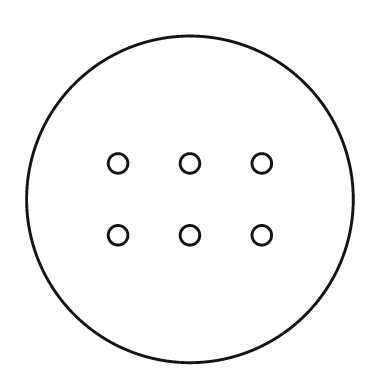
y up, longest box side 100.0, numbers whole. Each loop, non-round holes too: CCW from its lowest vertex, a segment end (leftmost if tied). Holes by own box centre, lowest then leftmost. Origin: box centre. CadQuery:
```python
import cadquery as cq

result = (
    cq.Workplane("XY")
    .moveTo(0.0, 0.0)
    .circle(50.0)
    .moveTo(-22.0, -11.0)
    .circle(3.0)
    .moveTo(0.0, -11.0)
    .circle(3.0)
    .moveTo(22.0, -11.0)
    .circle(3.0)
    .moveTo(-22.0, 11.0)
    .circle(3.0)
    .moveTo(0.0, 11.0)
    .circle(3.0)
    .moveTo(22.0, 11.0)
    .circle(3.0)
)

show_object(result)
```